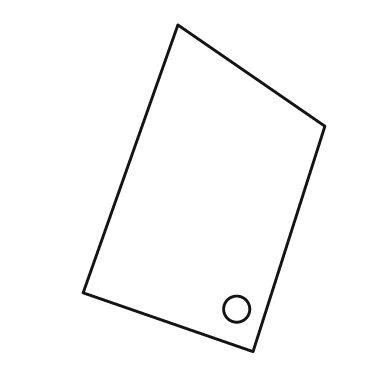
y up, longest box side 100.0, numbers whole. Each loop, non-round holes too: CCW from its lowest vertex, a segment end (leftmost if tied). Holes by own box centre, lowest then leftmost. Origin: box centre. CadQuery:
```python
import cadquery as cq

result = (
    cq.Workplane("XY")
    .moveTo(15.0, -50.0)
    .lineTo(37.0, 19.0)
    .lineTo(-8.0, 50.0)
    .lineTo(-37.0, -32.0)
    .close()
    .moveTo(10.0, -37.0)
    .circle(4.0)
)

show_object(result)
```